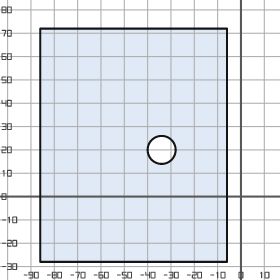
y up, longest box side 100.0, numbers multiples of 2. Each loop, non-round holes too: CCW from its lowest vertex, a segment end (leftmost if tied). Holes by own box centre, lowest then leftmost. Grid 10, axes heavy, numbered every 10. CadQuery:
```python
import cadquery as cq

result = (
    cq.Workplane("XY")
    .moveTo(-86.0, -28.0)
    .lineTo(-6.0, -28.0)
    .lineTo(-6.0, 72.0)
    .lineTo(-86.0, 72.0)
    .close()
    .moveTo(-34.0, 20.0)
    .circle(6.0)
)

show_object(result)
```